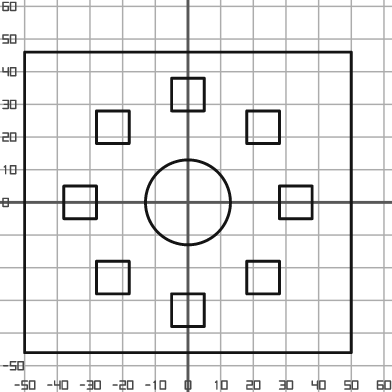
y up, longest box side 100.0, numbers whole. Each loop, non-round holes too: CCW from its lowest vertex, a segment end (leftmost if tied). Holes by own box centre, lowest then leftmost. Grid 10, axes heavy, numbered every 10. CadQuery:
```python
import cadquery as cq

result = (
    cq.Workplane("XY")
    .moveTo(-50.0, -46.0)
    .lineTo(50.0, -46.0)
    .lineTo(50.0, 46.0)
    .lineTo(-50.0, 46.0)
    .close()
    .moveTo(-5.0, -38.0)
    .lineTo(5.0, -38.0)
    .lineTo(5.0, -28.0)
    .lineTo(-5.0, -28.0)
    .close()
    .moveTo(-28.0, -28.0)
    .lineTo(-18.0, -28.0)
    .lineTo(-18.0, -18.0)
    .lineTo(-28.0, -18.0)
    .close()
    .moveTo(18.0, -28.0)
    .lineTo(28.0, -28.0)
    .lineTo(28.0, -18.0)
    .lineTo(18.0, -18.0)
    .close()
    .moveTo(-38.0, -5.0)
    .lineTo(-28.0, -5.0)
    .lineTo(-28.0, 5.0)
    .lineTo(-38.0, 5.0)
    .close()
    .moveTo(0.0, 0.0)
    .circle(13.0)
    .moveTo(28.0, -5.0)
    .lineTo(38.0, -5.0)
    .lineTo(38.0, 5.0)
    .lineTo(28.0, 5.0)
    .close()
    .moveTo(-28.0, 18.0)
    .lineTo(-18.0, 18.0)
    .lineTo(-18.0, 28.0)
    .lineTo(-28.0, 28.0)
    .close()
    .moveTo(18.0, 18.0)
    .lineTo(28.0, 18.0)
    .lineTo(28.0, 28.0)
    .lineTo(18.0, 28.0)
    .close()
    .moveTo(-5.0, 28.0)
    .lineTo(5.0, 28.0)
    .lineTo(5.0, 38.0)
    .lineTo(-5.0, 38.0)
    .close()
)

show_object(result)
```